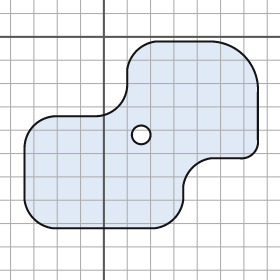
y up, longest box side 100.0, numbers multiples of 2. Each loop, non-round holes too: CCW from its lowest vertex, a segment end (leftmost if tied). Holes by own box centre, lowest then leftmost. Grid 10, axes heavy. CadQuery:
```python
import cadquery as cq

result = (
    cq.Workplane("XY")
    .moveTo(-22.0, -82.0)
    .lineTo(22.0, -82.0)
    .threePointArc((30.0, -78.0), (34.0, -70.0))
    .lineTo(34.0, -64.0)
    .threePointArc((38.0, -56.0), (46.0, -52.0))
    .lineTo(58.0, -52.0)
    .threePointArc((64.0, -50.0), (66.0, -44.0))
    .lineTo(66.0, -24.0)
    .threePointArc((60.0, -8.0), (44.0, -2.0))
    .lineTo(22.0, -2.0)
    .threePointArc((14.0, -6.0), (10.0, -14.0))
    .lineTo(10.0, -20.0)
    .threePointArc((6.0, -30.0), (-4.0, -34.0))
    .lineTo(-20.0, -34.0)
    .threePointArc((-30.0, -38.0), (-34.0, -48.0))
    .lineTo(-34.0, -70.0)
    .threePointArc((-30.0, -78.0), (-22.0, -82.0))
    .close()
    .moveTo(16.0, -42.0)
    .circle(4.0)
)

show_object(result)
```